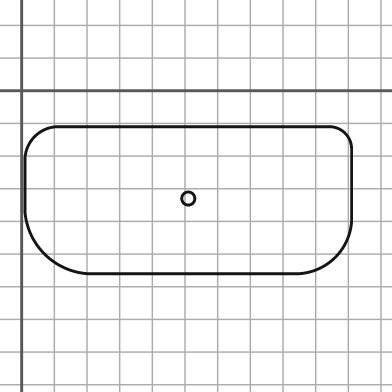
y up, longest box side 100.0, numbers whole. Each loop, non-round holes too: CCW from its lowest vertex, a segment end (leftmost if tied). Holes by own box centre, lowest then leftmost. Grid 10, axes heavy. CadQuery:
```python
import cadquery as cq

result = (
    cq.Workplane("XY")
    .moveTo(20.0, -56.0)
    .lineTo(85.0, -56.0)
    .threePointArc((96.0, -51.0), (101.0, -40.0))
    .lineTo(101.0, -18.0)
    .threePointArc((99.0, -13.0), (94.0, -11.0))
    .lineTo(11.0, -11.0)
    .threePointArc((4.0, -14.0), (1.0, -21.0))
    .lineTo(1.0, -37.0)
    .threePointArc((7.0, -50.0), (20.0, -56.0))
    .close()
    .moveTo(51.0, -33.0)
    .circle(2.0)
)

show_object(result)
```